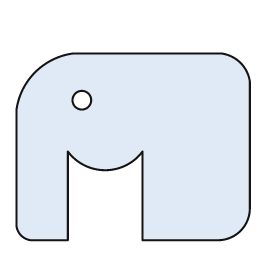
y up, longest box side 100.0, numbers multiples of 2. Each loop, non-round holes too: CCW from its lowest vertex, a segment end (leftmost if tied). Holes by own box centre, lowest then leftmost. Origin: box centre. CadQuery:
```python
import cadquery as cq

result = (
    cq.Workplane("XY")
    .moveTo(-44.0, -40.0)
    .lineTo(-28.0, -40.0)
    .lineTo(-28.0, -2.0)
    .threePointArc((-12.0, -10.0), (4.0, -2.0))
    .lineTo(4.0, -40.0)
    .lineTo(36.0, -40.0)
    .threePointArc((46.0, -36.0), (50.0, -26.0))
    .lineTo(50.0, 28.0)
    .threePointArc((46.0, 36.0), (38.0, 40.0))
    .lineTo(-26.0, 40.0)
    .threePointArc((-42.0, 32.0), (-50.0, 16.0))
    .lineTo(-50.0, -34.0)
    .threePointArc((-48.0, -38.0), (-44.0, -40.0))
    .close()
    .moveTo(-22.0, 20.0)
    .circle(4.0)
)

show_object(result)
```